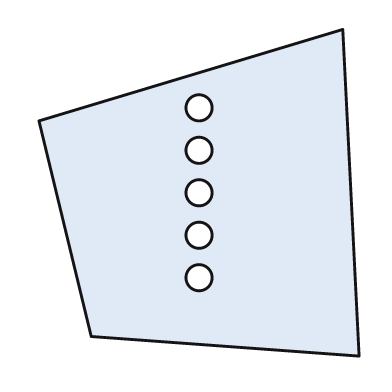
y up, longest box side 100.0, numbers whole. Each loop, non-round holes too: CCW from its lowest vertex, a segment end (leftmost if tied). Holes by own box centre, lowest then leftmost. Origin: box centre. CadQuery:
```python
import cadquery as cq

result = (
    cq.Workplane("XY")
    .moveTo(49.0, -50.0)
    .lineTo(44.0, 50.0)
    .lineTo(-49.0, 22.0)
    .lineTo(-33.0, -44.0)
    .close()
    .moveTo(0.0, -26.0)
    .circle(4.0)
    .moveTo(0.0, -13.0)
    .circle(4.0)
    .moveTo(0.0, 0.0)
    .circle(4.0)
    .moveTo(0.0, 13.0)
    .circle(4.0)
    .moveTo(0.0, 26.0)
    .circle(4.0)
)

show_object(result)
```